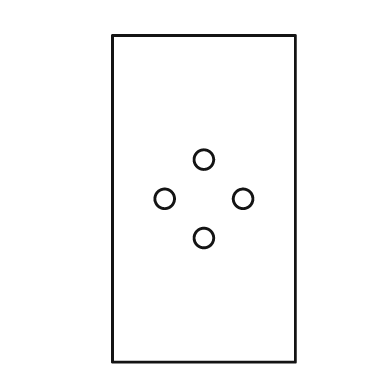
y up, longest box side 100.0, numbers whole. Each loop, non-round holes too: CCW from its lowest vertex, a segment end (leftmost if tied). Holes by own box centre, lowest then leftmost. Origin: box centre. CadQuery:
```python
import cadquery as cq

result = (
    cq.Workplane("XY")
    .moveTo(-28.0, -50.0)
    .lineTo(28.0, -50.0)
    .lineTo(28.0, 50.0)
    .lineTo(-28.0, 50.0)
    .close()
    .moveTo(0.0, -12.0)
    .circle(3.0)
    .moveTo(-12.0, 0.0)
    .circle(3.0)
    .moveTo(12.0, 0.0)
    .circle(3.0)
    .moveTo(0.0, 12.0)
    .circle(3.0)
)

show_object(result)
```